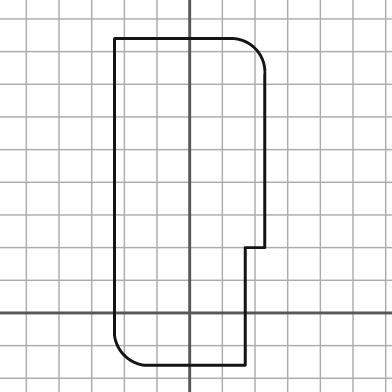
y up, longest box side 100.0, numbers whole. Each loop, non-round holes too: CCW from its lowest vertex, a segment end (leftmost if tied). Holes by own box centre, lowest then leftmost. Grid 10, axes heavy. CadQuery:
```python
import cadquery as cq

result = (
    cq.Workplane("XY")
    .moveTo(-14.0, -16.0)
    .lineTo(17.0, -16.0)
    .lineTo(17.0, 20.0)
    .lineTo(23.0, 20.0)
    .lineTo(23.0, 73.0)
    .threePointArc((20.0, 81.0), (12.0, 84.0))
    .lineTo(-23.0, 84.0)
    .lineTo(-23.0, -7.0)
    .threePointArc((-20.0, -13.0), (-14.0, -16.0))
    .close()
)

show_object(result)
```